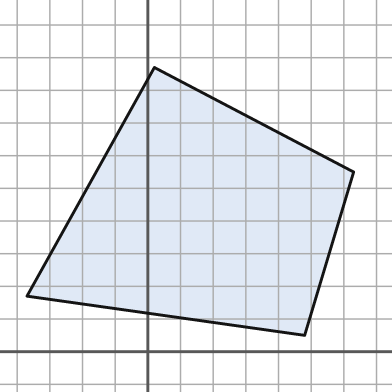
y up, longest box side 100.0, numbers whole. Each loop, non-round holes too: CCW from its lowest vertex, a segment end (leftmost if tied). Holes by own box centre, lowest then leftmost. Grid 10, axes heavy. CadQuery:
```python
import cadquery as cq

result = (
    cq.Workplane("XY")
    .moveTo(48.0, 5.0)
    .lineTo(63.0, 55.0)
    .lineTo(2.0, 87.0)
    .lineTo(-37.0, 17.0)
    .close()
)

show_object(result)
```